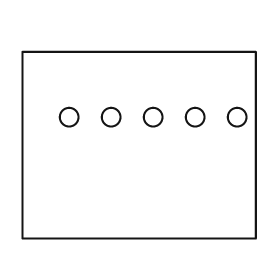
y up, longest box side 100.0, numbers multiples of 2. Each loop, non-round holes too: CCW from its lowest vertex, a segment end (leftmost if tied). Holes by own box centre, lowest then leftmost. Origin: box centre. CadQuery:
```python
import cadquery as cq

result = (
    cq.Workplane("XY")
    .moveTo(-50.0, -40.0)
    .lineTo(50.0, -40.0)
    .lineTo(50.0, 40.0)
    .lineTo(-50.0, 40.0)
    .close()
    .moveTo(-30.0, 12.0)
    .circle(4.0)
    .moveTo(-12.0, 12.0)
    .circle(4.0)
    .moveTo(6.0, 12.0)
    .circle(4.0)
    .moveTo(24.0, 12.0)
    .circle(4.0)
    .moveTo(42.0, 12.0)
    .circle(4.0)
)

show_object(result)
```